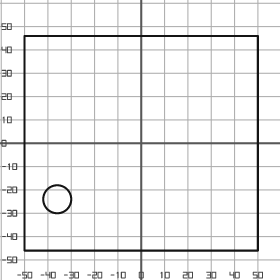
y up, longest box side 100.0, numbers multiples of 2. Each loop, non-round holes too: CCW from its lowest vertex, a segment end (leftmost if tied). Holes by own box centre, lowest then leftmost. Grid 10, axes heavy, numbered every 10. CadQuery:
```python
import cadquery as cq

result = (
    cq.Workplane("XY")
    .moveTo(-50.0, -46.0)
    .lineTo(50.0, -46.0)
    .lineTo(50.0, 46.0)
    .lineTo(-50.0, 46.0)
    .close()
    .moveTo(-36.0, -24.0)
    .circle(6.0)
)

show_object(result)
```